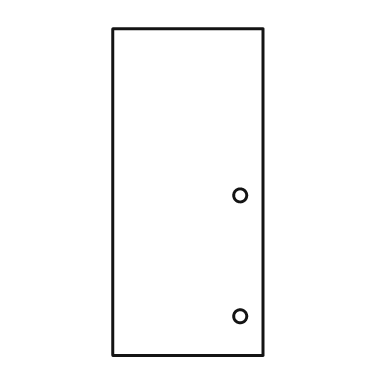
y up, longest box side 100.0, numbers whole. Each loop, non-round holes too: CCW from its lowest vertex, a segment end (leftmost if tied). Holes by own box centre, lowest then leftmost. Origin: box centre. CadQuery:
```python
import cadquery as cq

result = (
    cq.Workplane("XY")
    .moveTo(-23.0, -50.0)
    .lineTo(23.0, -50.0)
    .lineTo(23.0, 50.0)
    .lineTo(-23.0, 50.0)
    .close()
    .moveTo(16.0, -38.0)
    .circle(2.0)
    .moveTo(16.0, -1.0)
    .circle(2.0)
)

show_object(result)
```